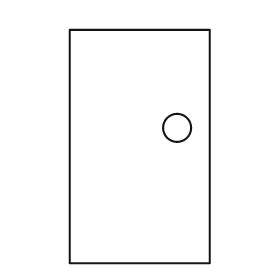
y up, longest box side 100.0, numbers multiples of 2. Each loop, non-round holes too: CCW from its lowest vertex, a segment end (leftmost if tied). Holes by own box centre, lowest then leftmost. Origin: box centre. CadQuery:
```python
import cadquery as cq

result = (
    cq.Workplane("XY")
    .moveTo(-30.0, -50.0)
    .lineTo(30.0, -50.0)
    .lineTo(30.0, 50.0)
    .lineTo(-30.0, 50.0)
    .close()
    .moveTo(16.0, 8.0)
    .circle(6.0)
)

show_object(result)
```